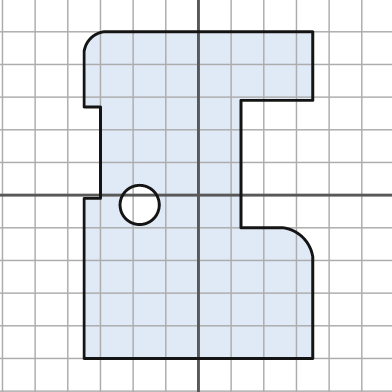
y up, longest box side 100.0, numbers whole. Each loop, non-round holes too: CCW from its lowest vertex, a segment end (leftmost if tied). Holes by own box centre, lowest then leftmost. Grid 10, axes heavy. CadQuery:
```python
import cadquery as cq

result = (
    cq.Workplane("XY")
    .moveTo(-35.0, -50.0)
    .lineTo(35.0, -50.0)
    .lineTo(35.0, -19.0)
    .threePointArc((32.0, -13.0), (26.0, -10.0))
    .lineTo(13.0, -10.0)
    .lineTo(13.0, 29.0)
    .lineTo(35.0, 29.0)
    .lineTo(35.0, 50.0)
    .lineTo(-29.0, 50.0)
    .threePointArc((-33.0, 48.0), (-35.0, 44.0))
    .lineTo(-35.0, 27.0)
    .lineTo(-30.0, 27.0)
    .lineTo(-30.0, -1.0)
    .lineTo(-35.0, -1.0)
    .close()
    .moveTo(-18.0, -3.0)
    .circle(6.0)
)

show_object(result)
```